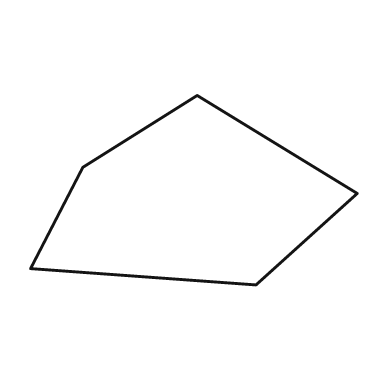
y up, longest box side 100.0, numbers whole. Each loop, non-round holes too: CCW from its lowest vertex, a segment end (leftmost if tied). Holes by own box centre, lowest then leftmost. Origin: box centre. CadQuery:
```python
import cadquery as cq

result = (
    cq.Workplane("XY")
    .moveTo(19.0, -29.0)
    .lineTo(50.0, -1.0)
    .lineTo(1.0, 29.0)
    .lineTo(-34.0, 7.0)
    .lineTo(-50.0, -24.0)
    .close()
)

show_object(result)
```